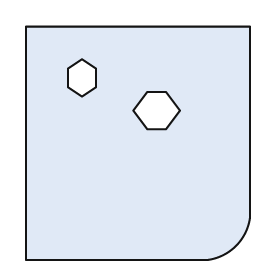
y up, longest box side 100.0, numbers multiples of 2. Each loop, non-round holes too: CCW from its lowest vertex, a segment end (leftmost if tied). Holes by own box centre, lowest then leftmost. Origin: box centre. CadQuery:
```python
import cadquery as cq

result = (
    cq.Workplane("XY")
    .moveTo(-48.0, -50.0)
    .lineTo(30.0, -50.0)
    .threePointArc((42.0, -44.0), (48.0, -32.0))
    .lineTo(48.0, 50.0)
    .lineTo(-48.0, 50.0)
    .close()
    .moveTo(4.0, 6.0)
    .lineTo(12.0, 6.0)
    .lineTo(18.0, 14.0)
    .lineTo(12.0, 22.0)
    .lineTo(4.0, 22.0)
    .lineTo(-2.0, 14.0)
    .close()
    .moveTo(-24.0, 20.0)
    .lineTo(-18.0, 24.0)
    .lineTo(-18.0, 32.0)
    .lineTo(-24.0, 36.0)
    .lineTo(-30.0, 32.0)
    .lineTo(-30.0, 24.0)
    .close()
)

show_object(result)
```